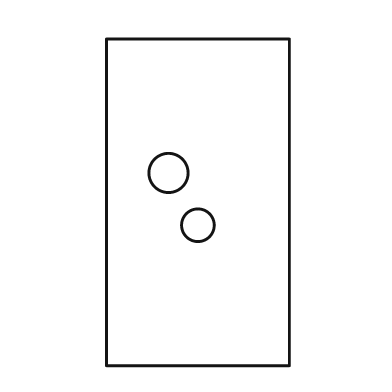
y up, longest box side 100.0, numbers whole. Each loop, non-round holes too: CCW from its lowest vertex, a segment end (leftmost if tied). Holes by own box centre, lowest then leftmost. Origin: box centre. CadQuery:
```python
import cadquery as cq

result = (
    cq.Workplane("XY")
    .moveTo(-28.0, -50.0)
    .lineTo(28.0, -50.0)
    .lineTo(28.0, 50.0)
    .lineTo(-28.0, 50.0)
    .close()
    .moveTo(0.0, -7.0)
    .circle(5.0)
    .moveTo(-9.0, 9.0)
    .circle(6.0)
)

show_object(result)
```